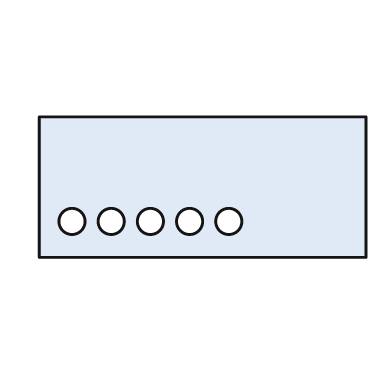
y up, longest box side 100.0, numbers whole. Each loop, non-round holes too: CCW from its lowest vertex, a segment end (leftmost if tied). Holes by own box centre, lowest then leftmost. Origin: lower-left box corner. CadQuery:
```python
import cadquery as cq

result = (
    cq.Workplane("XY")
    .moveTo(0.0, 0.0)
    .lineTo(100.0, 0.0)
    .lineTo(100.0, 43.0)
    .lineTo(0.0, 43.0)
    .close()
    .moveTo(10.0, 11.0)
    .circle(4.0)
    .moveTo(22.0, 11.0)
    .circle(4.0)
    .moveTo(34.0, 11.0)
    .circle(4.0)
    .moveTo(46.0, 11.0)
    .circle(4.0)
    .moveTo(58.0, 11.0)
    .circle(4.0)
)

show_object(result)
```